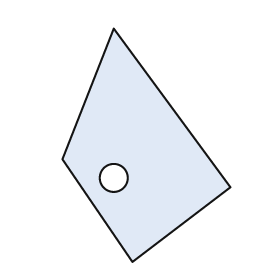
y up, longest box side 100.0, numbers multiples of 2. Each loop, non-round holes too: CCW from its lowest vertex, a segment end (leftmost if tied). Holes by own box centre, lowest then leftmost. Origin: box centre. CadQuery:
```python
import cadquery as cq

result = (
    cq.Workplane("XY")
    .moveTo(-6.0, -50.0)
    .lineTo(36.0, -18.0)
    .lineTo(-14.0, 50.0)
    .lineTo(-36.0, -6.0)
    .close()
    .moveTo(-14.0, -14.0)
    .circle(6.0)
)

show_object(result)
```